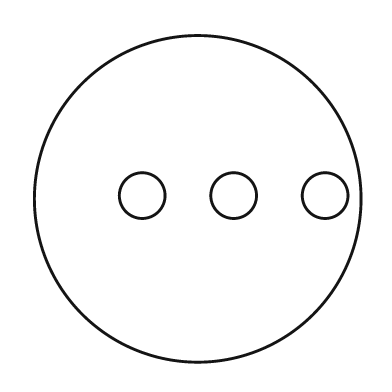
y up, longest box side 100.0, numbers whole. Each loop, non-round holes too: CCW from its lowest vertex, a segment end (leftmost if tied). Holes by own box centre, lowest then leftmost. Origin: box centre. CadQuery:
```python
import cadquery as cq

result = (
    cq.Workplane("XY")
    .moveTo(0.0, 0.0)
    .circle(50.0)
    .moveTo(-17.0, 1.0)
    .circle(7.0)
    .moveTo(11.0, 1.0)
    .circle(7.0)
    .moveTo(39.0, 1.0)
    .circle(7.0)
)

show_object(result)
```